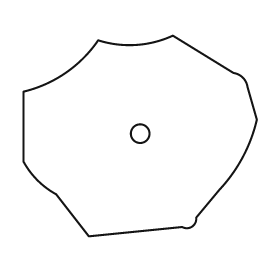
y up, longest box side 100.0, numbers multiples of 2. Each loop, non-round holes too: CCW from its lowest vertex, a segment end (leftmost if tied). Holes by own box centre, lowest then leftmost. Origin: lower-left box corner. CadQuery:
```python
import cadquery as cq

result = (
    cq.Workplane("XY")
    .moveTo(28.0, 0.0)
    .lineTo(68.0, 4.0)
    .threePointArc((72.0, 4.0), (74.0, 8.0))
    .lineTo(84.0, 20.0)
    .threePointArc((94.0, 34.0), (100.0, 50.0))
    .lineTo(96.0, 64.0)
    .threePointArc((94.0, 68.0), (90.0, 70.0))
    .lineTo(64.0, 86.0)
    .threePointArc((48.0, 82.0), (32.0, 84.0))
    .threePointArc((18.0, 70.0), (0.0, 62.0))
    .lineTo(0.0, 32.0)
    .threePointArc((6.0, 24.0), (14.0, 18.0))
    .close()
    .moveTo(50.0, 44.0)
    .circle(4.0)
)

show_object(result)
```